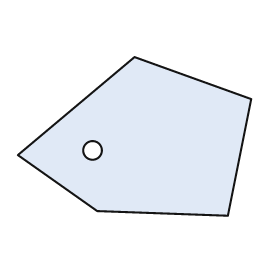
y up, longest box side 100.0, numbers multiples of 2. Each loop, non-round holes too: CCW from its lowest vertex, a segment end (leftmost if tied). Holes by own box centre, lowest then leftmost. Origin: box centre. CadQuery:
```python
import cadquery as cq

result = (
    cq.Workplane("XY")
    .moveTo(40.0, -34.0)
    .lineTo(50.0, 16.0)
    .lineTo(0.0, 34.0)
    .lineTo(-50.0, -8.0)
    .lineTo(-16.0, -32.0)
    .close()
    .moveTo(-18.0, -6.0)
    .circle(4.0)
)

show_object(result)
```